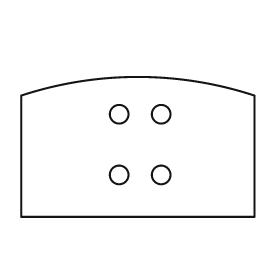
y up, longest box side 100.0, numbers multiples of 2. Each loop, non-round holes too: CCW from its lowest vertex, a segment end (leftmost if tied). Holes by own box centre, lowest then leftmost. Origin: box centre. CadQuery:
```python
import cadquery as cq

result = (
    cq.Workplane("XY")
    .moveTo(-50.0, -30.0)
    .lineTo(50.0, -30.0)
    .lineTo(50.0, 22.0)
    .threePointArc((0.0, 30.0), (-50.0, 22.0))
    .close()
    .moveTo(-8.0, -12.0)
    .circle(4.0)
    .moveTo(10.0, -12.0)
    .circle(4.0)
    .moveTo(-8.0, 14.0)
    .circle(4.0)
    .moveTo(10.0, 14.0)
    .circle(4.0)
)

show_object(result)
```